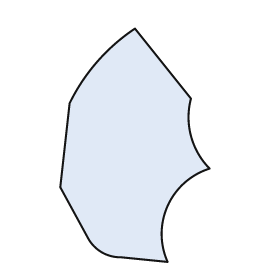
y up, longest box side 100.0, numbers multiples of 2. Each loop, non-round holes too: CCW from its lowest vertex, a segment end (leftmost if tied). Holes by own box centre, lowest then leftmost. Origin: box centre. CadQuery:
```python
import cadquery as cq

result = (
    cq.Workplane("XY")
    .moveTo(14.0, -50.0)
    .threePointArc((14.0, -26.0), (32.0, -10.0))
    .threePointArc((24.0, 4.0), (24.0, 20.0))
    .lineTo(0.0, 50.0)
    .threePointArc((-16.0, 36.0), (-28.0, 18.0))
    .lineTo(-32.0, -18.0)
    .lineTo(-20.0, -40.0)
    .threePointArc((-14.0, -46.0), (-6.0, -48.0))
    .close()
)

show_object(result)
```